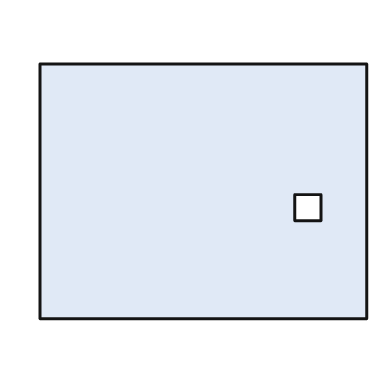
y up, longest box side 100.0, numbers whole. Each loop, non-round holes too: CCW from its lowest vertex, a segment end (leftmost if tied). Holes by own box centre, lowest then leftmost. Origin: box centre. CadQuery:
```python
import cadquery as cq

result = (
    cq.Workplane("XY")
    .moveTo(-50.0, -39.0)
    .lineTo(50.0, -39.0)
    .lineTo(50.0, 39.0)
    .lineTo(-50.0, 39.0)
    .close()
    .moveTo(28.0, -9.0)
    .lineTo(36.0, -9.0)
    .lineTo(36.0, -1.0)
    .lineTo(28.0, -1.0)
    .close()
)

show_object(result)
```